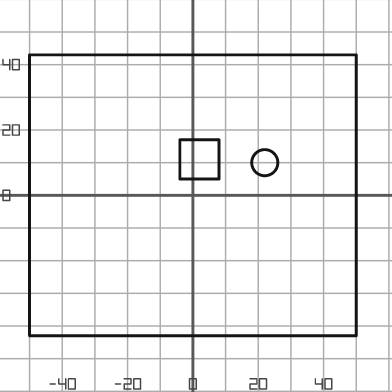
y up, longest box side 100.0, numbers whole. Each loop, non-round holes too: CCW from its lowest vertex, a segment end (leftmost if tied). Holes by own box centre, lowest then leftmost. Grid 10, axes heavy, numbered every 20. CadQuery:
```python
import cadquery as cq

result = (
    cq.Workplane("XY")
    .moveTo(-50.0, -43.0)
    .lineTo(50.0, -43.0)
    .lineTo(50.0, 43.0)
    .lineTo(-50.0, 43.0)
    .close()
    .moveTo(22.0, 10.0)
    .circle(4.0)
    .moveTo(-4.0, 5.0)
    .lineTo(8.0, 5.0)
    .lineTo(8.0, 17.0)
    .lineTo(-4.0, 17.0)
    .close()
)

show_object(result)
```